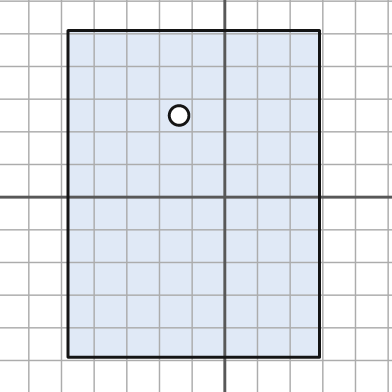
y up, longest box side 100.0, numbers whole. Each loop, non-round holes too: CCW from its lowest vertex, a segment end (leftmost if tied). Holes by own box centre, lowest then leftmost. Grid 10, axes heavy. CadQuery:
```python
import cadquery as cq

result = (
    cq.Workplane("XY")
    .moveTo(-48.0, -49.0)
    .lineTo(29.0, -49.0)
    .lineTo(29.0, 51.0)
    .lineTo(-48.0, 51.0)
    .close()
    .moveTo(-14.0, 25.0)
    .circle(3.0)
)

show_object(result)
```